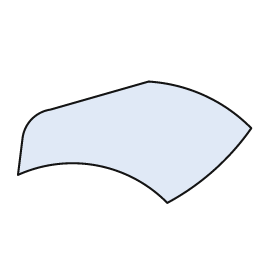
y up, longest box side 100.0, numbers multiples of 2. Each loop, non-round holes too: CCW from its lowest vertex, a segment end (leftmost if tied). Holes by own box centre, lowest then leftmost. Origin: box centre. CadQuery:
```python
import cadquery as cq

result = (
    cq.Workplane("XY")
    .moveTo(14.0, -26.0)
    .threePointArc((34.0, -12.0), (50.0, 6.0))
    .threePointArc((30.0, 20.0), (6.0, 26.0))
    .lineTo(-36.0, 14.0)
    .threePointArc((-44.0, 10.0), (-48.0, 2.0))
    .lineTo(-50.0, -14.0)
    .threePointArc((-16.0, -10.0), (14.0, -26.0))
    .close()
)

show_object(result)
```